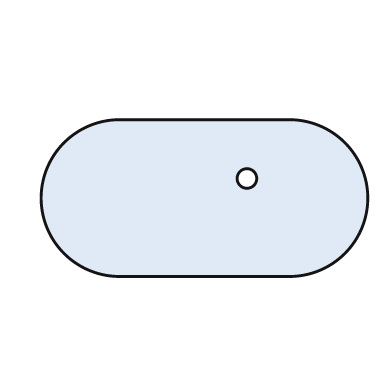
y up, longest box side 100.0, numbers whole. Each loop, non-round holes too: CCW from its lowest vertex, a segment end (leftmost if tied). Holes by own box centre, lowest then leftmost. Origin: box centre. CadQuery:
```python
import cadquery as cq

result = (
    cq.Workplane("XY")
    .moveTo(-26.0, -24.0)
    .lineTo(26.0, -24.0)
    .threePointArc((50.0, 0.0), (26.0, 24.0))
    .lineTo(-26.0, 24.0)
    .threePointArc((-50.0, 0.0), (-26.0, -24.0))
    .close()
    .moveTo(13.0, 6.0)
    .circle(3.0)
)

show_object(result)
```